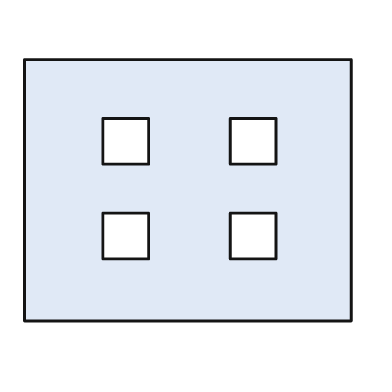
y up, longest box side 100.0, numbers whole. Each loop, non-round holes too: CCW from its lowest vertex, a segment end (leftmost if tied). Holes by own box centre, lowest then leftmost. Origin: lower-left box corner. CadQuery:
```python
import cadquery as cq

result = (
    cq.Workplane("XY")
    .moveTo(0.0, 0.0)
    .lineTo(100.0, 0.0)
    .lineTo(100.0, 80.0)
    .lineTo(0.0, 80.0)
    .close()
    .moveTo(24.0, 19.0)
    .lineTo(38.0, 19.0)
    .lineTo(38.0, 33.0)
    .lineTo(24.0, 33.0)
    .close()
    .moveTo(63.0, 19.0)
    .lineTo(77.0, 19.0)
    .lineTo(77.0, 33.0)
    .lineTo(63.0, 33.0)
    .close()
    .moveTo(24.0, 48.0)
    .lineTo(38.0, 48.0)
    .lineTo(38.0, 62.0)
    .lineTo(24.0, 62.0)
    .close()
    .moveTo(63.0, 48.0)
    .lineTo(77.0, 48.0)
    .lineTo(77.0, 62.0)
    .lineTo(63.0, 62.0)
    .close()
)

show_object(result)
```